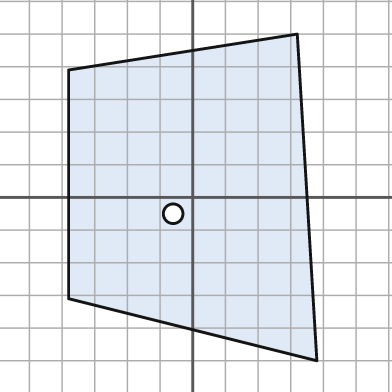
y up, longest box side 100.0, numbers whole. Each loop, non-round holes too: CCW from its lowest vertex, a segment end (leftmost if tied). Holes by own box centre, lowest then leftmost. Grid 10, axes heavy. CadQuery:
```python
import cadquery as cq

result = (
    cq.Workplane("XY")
    .moveTo(38.0, -50.0)
    .lineTo(32.0, 50.0)
    .lineTo(-38.0, 39.0)
    .lineTo(-38.0, -31.0)
    .close()
    .moveTo(-6.0, -5.0)
    .circle(3.0)
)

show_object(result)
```